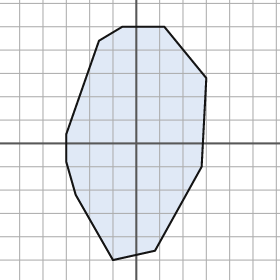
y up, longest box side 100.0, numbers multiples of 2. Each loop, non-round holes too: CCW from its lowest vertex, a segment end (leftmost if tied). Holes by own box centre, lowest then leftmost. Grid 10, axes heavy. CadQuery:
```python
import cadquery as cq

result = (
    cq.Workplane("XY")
    .moveTo(-10.0, -50.0)
    .lineTo(8.0, -46.0)
    .lineTo(28.0, -10.0)
    .lineTo(30.0, 28.0)
    .lineTo(12.0, 50.0)
    .lineTo(-6.0, 50.0)
    .lineTo(-16.0, 44.0)
    .lineTo(-30.0, 4.0)
    .lineTo(-30.0, -8.0)
    .lineTo(-26.0, -22.0)
    .close()
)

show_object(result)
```